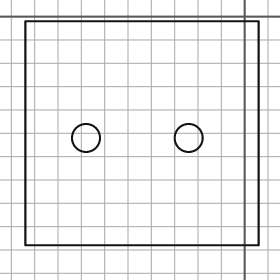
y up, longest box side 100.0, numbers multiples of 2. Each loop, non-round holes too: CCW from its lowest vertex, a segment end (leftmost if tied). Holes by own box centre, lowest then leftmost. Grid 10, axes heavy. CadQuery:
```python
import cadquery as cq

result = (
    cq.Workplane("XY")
    .moveTo(-94.0, -98.0)
    .lineTo(6.0, -98.0)
    .lineTo(6.0, -2.0)
    .lineTo(-94.0, -2.0)
    .close()
    .moveTo(-68.0, -52.0)
    .circle(6.0)
    .moveTo(-24.0, -52.0)
    .circle(6.0)
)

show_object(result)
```